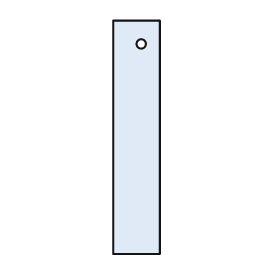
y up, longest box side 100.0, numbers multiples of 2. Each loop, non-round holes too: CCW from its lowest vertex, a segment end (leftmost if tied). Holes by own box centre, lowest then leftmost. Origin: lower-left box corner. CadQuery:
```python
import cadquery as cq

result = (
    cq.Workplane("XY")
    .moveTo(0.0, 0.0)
    .lineTo(20.0, 0.0)
    .lineTo(20.0, 100.0)
    .lineTo(0.0, 100.0)
    .close()
    .moveTo(12.0, 90.0)
    .circle(2.0)
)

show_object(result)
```